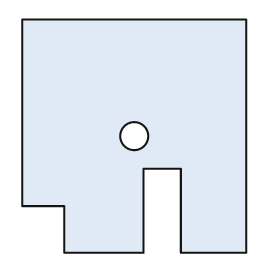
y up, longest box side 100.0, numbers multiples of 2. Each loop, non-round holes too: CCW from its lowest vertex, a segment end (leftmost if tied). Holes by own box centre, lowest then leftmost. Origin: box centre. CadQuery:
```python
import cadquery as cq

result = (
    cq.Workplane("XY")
    .moveTo(-30.0, -50.0)
    .lineTo(4.0, -50.0)
    .lineTo(4.0, -14.0)
    .lineTo(20.0, -14.0)
    .lineTo(20.0, -50.0)
    .lineTo(48.0, -50.0)
    .lineTo(48.0, 50.0)
    .lineTo(-48.0, 50.0)
    .lineTo(-48.0, -30.0)
    .lineTo(-30.0, -30.0)
    .close()
    .moveTo(0.0, 0.0)
    .circle(6.0)
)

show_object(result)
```